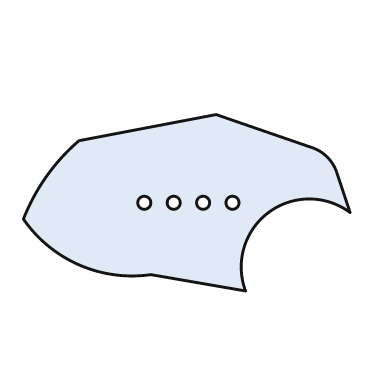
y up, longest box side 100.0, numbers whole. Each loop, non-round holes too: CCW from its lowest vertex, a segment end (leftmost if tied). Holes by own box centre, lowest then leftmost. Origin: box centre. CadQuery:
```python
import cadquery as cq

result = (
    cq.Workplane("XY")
    .moveTo(18.0, -27.0)
    .threePointArc((25.0, -3.0), (50.0, -3.0))
    .lineTo(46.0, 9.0)
    .threePointArc((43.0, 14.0), (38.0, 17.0))
    .lineTo(9.0, 27.0)
    .lineTo(-33.0, 19.0)
    .threePointArc((-43.0, 8.0), (-50.0, -5.0))
    .threePointArc((-33.0, -19.0), (-11.0, -22.0))
    .close()
    .moveTo(-13.0, 0.0)
    .circle(2.0)
    .moveTo(-4.0, 0.0)
    .circle(2.0)
    .moveTo(5.0, 0.0)
    .circle(2.0)
    .moveTo(14.0, 0.0)
    .circle(2.0)
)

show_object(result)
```